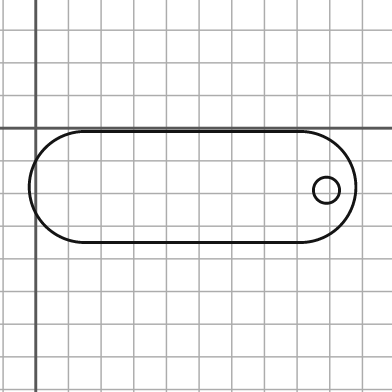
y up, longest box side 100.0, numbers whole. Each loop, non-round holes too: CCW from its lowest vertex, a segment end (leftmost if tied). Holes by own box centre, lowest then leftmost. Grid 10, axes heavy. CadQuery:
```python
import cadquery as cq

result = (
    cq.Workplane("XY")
    .moveTo(15.0, -35.0)
    .lineTo(81.0, -35.0)
    .threePointArc((98.0, -18.0), (81.0, -1.0))
    .lineTo(15.0, -1.0)
    .threePointArc((-2.0, -18.0), (15.0, -35.0))
    .close()
    .moveTo(89.0, -19.0)
    .circle(4.0)
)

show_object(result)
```